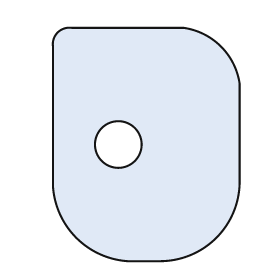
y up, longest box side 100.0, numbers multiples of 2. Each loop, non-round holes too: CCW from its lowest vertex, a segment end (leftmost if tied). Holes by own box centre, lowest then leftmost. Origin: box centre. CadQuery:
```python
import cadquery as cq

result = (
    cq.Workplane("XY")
    .moveTo(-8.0, -50.0)
    .lineTo(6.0, -50.0)
    .threePointArc((30.0, -40.0), (40.0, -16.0))
    .lineTo(40.0, 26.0)
    .threePointArc((32.0, 42.0), (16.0, 50.0))
    .lineTo(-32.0, 50.0)
    .threePointArc((-38.0, 48.0), (-40.0, 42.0))
    .lineTo(-40.0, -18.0)
    .threePointArc((-30.0, -40.0), (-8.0, -50.0))
    .close()
    .moveTo(-12.0, 0.0)
    .circle(10.0)
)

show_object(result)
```